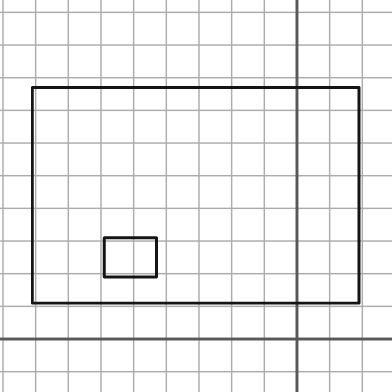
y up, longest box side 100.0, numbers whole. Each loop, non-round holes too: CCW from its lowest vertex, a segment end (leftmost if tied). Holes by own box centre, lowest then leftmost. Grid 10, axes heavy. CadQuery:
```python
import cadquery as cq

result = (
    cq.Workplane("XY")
    .moveTo(-81.0, 11.0)
    .lineTo(19.0, 11.0)
    .lineTo(19.0, 77.0)
    .lineTo(-81.0, 77.0)
    .close()
    .moveTo(-59.0, 19.0)
    .lineTo(-43.0, 19.0)
    .lineTo(-43.0, 31.0)
    .lineTo(-59.0, 31.0)
    .close()
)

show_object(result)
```